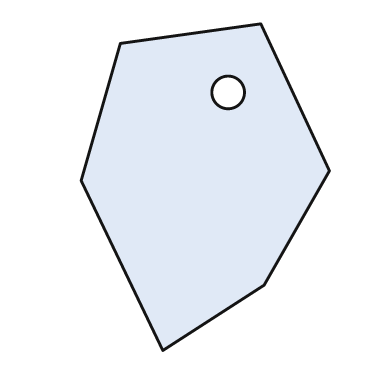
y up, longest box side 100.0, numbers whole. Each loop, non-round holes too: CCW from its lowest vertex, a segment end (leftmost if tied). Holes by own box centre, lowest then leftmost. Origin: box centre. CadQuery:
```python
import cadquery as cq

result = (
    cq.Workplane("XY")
    .moveTo(-13.0, -50.0)
    .lineTo(18.0, -30.0)
    .lineTo(38.0, 5.0)
    .lineTo(17.0, 50.0)
    .lineTo(-26.0, 44.0)
    .lineTo(-38.0, 2.0)
    .close()
    .moveTo(7.0, 29.0)
    .circle(5.0)
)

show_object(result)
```